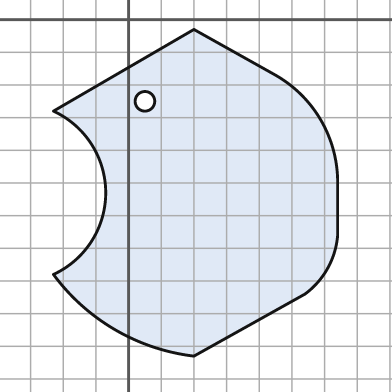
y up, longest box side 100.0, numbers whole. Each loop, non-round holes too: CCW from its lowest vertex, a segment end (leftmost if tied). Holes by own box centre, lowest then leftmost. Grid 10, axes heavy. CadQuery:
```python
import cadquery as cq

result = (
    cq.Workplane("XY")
    .moveTo(20.0, -103.0)
    .lineTo(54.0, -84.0)
    .threePointArc((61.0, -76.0), (64.0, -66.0))
    .lineTo(64.0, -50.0)
    .threePointArc((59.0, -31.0), (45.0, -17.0))
    .lineTo(20.0, -3.0)
    .lineTo(-23.0, -28.0)
    .threePointArc((-7.0, -53.0), (-23.0, -78.0))
    .threePointArc((-4.0, -95.0), (20.0, -103.0))
    .close()
    .moveTo(5.0, -25.0)
    .circle(3.0)
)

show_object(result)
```